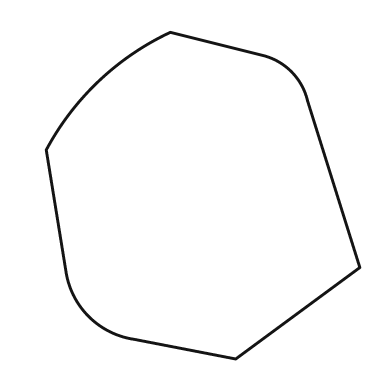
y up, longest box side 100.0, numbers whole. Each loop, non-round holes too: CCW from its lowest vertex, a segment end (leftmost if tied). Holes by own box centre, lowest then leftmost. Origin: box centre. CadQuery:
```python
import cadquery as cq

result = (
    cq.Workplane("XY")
    .moveTo(10.0, -50.0)
    .lineTo(48.0, -22.0)
    .lineTo(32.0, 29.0)
    .threePointArc((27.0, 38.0), (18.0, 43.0))
    .lineTo(-10.0, 50.0)
    .threePointArc((-32.0, 35.0), (-48.0, 14.0))
    .lineTo(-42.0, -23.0)
    .threePointArc((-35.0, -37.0), (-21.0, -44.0))
    .close()
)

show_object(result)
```